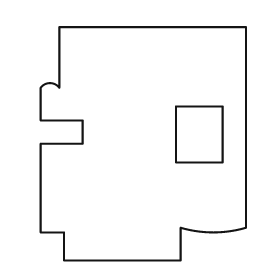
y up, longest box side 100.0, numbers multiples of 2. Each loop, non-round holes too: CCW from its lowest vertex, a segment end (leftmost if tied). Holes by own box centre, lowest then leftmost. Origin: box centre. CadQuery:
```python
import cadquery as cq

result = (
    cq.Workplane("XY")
    .moveTo(-34.0, -50.0)
    .lineTo(16.0, -50.0)
    .lineTo(16.0, -36.0)
    .threePointArc((30.0, -38.0), (44.0, -36.0))
    .lineTo(44.0, 50.0)
    .lineTo(-36.0, 50.0)
    .lineTo(-36.0, 24.0)
    .threePointArc((-40.0, 26.0), (-44.0, 24.0))
    .lineTo(-44.0, 10.0)
    .lineTo(-26.0, 10.0)
    .lineTo(-26.0, 0.0)
    .lineTo(-44.0, 0.0)
    .lineTo(-44.0, -38.0)
    .lineTo(-34.0, -38.0)
    .close()
    .moveTo(14.0, -8.0)
    .lineTo(34.0, -8.0)
    .lineTo(34.0, 16.0)
    .lineTo(14.0, 16.0)
    .close()
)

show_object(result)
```